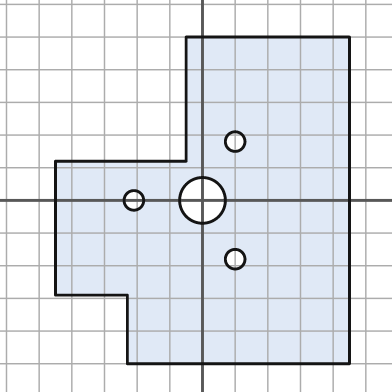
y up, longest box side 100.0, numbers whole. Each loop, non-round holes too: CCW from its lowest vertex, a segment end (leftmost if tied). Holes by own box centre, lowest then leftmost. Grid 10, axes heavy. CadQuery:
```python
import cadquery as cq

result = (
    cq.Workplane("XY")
    .moveTo(-23.0, -50.0)
    .lineTo(45.0, -50.0)
    .lineTo(45.0, 50.0)
    .lineTo(-5.0, 50.0)
    .lineTo(-5.0, 12.0)
    .lineTo(-45.0, 12.0)
    .lineTo(-45.0, -29.0)
    .lineTo(-23.0, -29.0)
    .close()
    .moveTo(10.0, -18.0)
    .circle(3.0)
    .moveTo(-21.0, 0.0)
    .circle(3.0)
    .moveTo(0.0, 0.0)
    .circle(7.0)
    .moveTo(10.0, 18.0)
    .circle(3.0)
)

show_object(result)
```